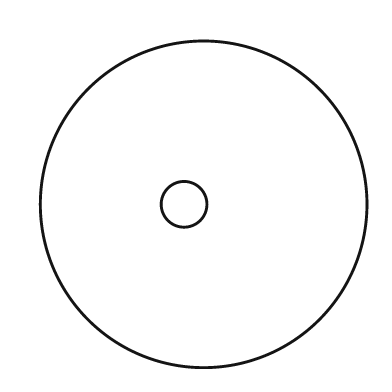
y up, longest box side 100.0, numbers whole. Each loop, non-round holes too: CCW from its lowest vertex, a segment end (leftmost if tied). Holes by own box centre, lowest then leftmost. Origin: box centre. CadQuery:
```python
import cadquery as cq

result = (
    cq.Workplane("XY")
    .moveTo(0.0, 0.0)
    .circle(50.0)
    .moveTo(-6.0, 0.0)
    .circle(7.0)
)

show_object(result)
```